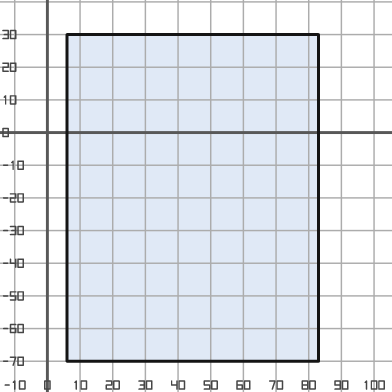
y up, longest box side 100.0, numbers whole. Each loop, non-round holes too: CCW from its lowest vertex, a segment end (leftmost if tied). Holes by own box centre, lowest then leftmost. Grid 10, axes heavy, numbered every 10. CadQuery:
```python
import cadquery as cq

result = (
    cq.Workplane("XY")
    .moveTo(6.0, -70.0)
    .lineTo(83.0, -70.0)
    .lineTo(83.0, 30.0)
    .lineTo(6.0, 30.0)
    .close()
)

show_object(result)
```